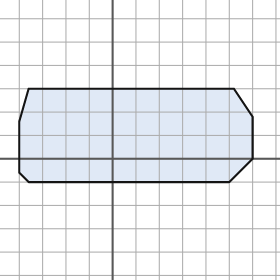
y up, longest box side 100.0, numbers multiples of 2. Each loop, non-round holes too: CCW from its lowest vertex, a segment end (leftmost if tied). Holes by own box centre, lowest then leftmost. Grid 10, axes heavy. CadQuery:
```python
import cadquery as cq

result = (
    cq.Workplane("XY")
    .moveTo(-36.0, -10.0)
    .lineTo(50.0, -10.0)
    .lineTo(60.0, 0.0)
    .lineTo(60.0, 18.0)
    .lineTo(52.0, 30.0)
    .lineTo(-36.0, 30.0)
    .lineTo(-40.0, 16.0)
    .lineTo(-40.0, -6.0)
    .close()
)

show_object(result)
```